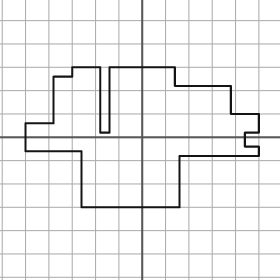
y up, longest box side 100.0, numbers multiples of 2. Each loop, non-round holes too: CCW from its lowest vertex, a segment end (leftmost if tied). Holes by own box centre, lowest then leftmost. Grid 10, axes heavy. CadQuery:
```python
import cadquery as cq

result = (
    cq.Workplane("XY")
    .moveTo(-26.0, -30.0)
    .lineTo(16.0, -30.0)
    .lineTo(16.0, -8.0)
    .lineTo(50.0, -8.0)
    .lineTo(50.0, -4.0)
    .lineTo(44.0, -4.0)
    .lineTo(44.0, 2.0)
    .lineTo(50.0, 2.0)
    .lineTo(50.0, 10.0)
    .lineTo(38.0, 10.0)
    .lineTo(38.0, 22.0)
    .lineTo(14.0, 22.0)
    .lineTo(14.0, 30.0)
    .lineTo(-14.0, 30.0)
    .lineTo(-14.0, 2.0)
    .lineTo(-18.0, 2.0)
    .lineTo(-18.0, 30.0)
    .lineTo(-30.0, 30.0)
    .lineTo(-30.0, 26.0)
    .lineTo(-38.0, 26.0)
    .lineTo(-38.0, 6.0)
    .lineTo(-50.0, 6.0)
    .lineTo(-50.0, -6.0)
    .lineTo(-26.0, -6.0)
    .close()
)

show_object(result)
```